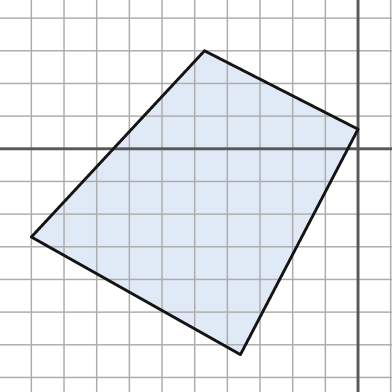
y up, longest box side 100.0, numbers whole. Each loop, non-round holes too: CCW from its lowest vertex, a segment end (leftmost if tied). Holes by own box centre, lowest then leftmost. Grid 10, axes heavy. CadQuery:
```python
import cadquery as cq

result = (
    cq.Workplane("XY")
    .moveTo(-36.0, -63.0)
    .lineTo(0.0, 6.0)
    .lineTo(-47.0, 30.0)
    .lineTo(-100.0, -27.0)
    .close()
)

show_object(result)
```